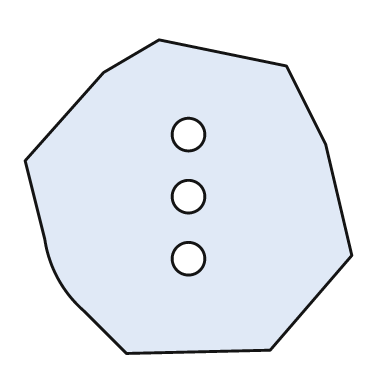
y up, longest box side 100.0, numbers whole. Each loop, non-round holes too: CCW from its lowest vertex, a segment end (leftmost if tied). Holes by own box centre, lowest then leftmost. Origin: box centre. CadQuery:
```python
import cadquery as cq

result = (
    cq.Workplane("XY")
    .moveTo(-19.0, -48.0)
    .lineTo(25.0, -47.0)
    .lineTo(50.0, -18.0)
    .lineTo(42.0, 16.0)
    .lineTo(30.0, 40.0)
    .lineTo(-9.0, 48.0)
    .lineTo(-26.0, 38.0)
    .lineTo(-50.0, 11.0)
    .lineTo(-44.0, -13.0)
    .threePointArc((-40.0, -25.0), (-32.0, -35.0))
    .close()
    .moveTo(0.0, -19.0)
    .circle(5.0)
    .moveTo(0.0, 0.0)
    .circle(5.0)
    .moveTo(0.0, 19.0)
    .circle(5.0)
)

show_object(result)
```